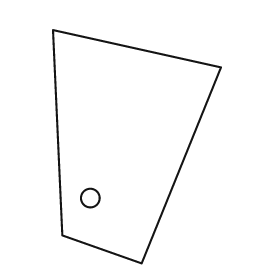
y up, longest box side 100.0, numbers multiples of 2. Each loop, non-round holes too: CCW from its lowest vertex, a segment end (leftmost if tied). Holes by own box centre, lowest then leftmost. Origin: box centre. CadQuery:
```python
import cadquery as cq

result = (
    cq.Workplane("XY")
    .moveTo(2.0, -50.0)
    .lineTo(36.0, 34.0)
    .lineTo(-36.0, 50.0)
    .lineTo(-32.0, -38.0)
    .close()
    .moveTo(-20.0, -22.0)
    .circle(4.0)
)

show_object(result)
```